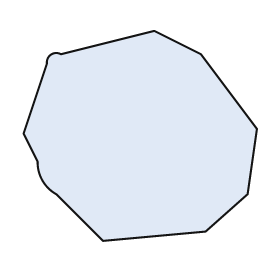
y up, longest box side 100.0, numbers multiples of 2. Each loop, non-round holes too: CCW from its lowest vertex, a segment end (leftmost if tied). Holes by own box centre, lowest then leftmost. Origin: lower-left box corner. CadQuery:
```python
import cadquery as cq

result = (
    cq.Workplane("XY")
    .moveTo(34.0, 0.0)
    .lineTo(78.0, 4.0)
    .lineTo(96.0, 20.0)
    .lineTo(100.0, 48.0)
    .lineTo(76.0, 80.0)
    .lineTo(56.0, 90.0)
    .lineTo(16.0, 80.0)
    .threePointArc((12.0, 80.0), (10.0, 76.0))
    .lineTo(0.0, 46.0)
    .lineTo(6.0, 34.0)
    .threePointArc((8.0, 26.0), (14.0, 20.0))
    .close()
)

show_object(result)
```